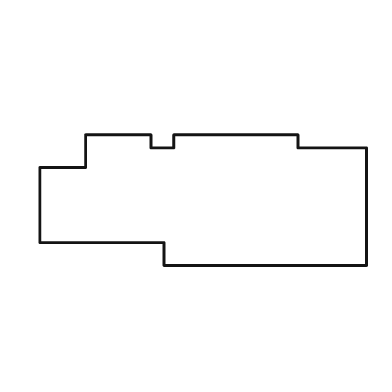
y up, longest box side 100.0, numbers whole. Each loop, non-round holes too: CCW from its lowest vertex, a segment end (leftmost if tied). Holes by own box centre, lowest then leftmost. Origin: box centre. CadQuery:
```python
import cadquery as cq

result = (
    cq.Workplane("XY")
    .moveTo(-12.0, -20.0)
    .lineTo(50.0, -20.0)
    .lineTo(50.0, 16.0)
    .lineTo(29.0, 16.0)
    .lineTo(29.0, 20.0)
    .lineTo(-9.0, 20.0)
    .lineTo(-9.0, 16.0)
    .lineTo(-16.0, 16.0)
    .lineTo(-16.0, 20.0)
    .lineTo(-36.0, 20.0)
    .lineTo(-36.0, 10.0)
    .lineTo(-50.0, 10.0)
    .lineTo(-50.0, -13.0)
    .lineTo(-12.0, -13.0)
    .close()
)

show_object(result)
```